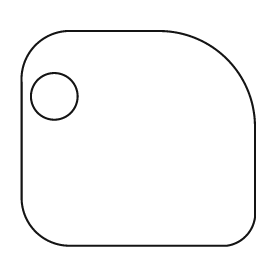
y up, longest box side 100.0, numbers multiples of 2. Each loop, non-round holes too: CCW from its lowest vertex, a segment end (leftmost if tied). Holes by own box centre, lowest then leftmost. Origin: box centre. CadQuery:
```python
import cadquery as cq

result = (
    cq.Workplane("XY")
    .moveTo(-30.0, -46.0)
    .lineTo(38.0, -46.0)
    .threePointArc((46.0, -42.0), (50.0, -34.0))
    .lineTo(50.0, 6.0)
    .threePointArc((38.0, 34.0), (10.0, 46.0))
    .lineTo(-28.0, 46.0)
    .threePointArc((-44.0, 40.0), (-50.0, 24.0))
    .lineTo(-50.0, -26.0)
    .threePointArc((-44.0, -40.0), (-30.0, -46.0))
    .close()
    .moveTo(-36.0, 18.0)
    .circle(10.0)
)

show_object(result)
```